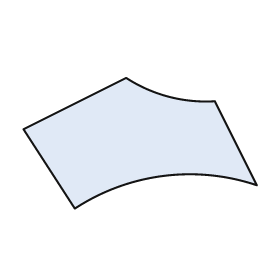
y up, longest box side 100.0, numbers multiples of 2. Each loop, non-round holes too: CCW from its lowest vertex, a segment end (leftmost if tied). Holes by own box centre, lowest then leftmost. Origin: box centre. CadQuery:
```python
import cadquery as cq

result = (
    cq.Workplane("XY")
    .moveTo(-28.0, -28.0)
    .threePointArc((10.0, -14.0), (50.0, -18.0))
    .lineTo(32.0, 18.0)
    .threePointArc((12.0, 20.0), (-6.0, 28.0))
    .lineTo(-50.0, 6.0)
    .close()
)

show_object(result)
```